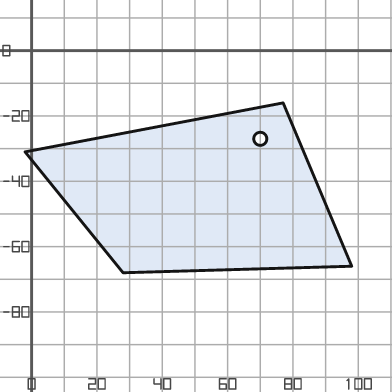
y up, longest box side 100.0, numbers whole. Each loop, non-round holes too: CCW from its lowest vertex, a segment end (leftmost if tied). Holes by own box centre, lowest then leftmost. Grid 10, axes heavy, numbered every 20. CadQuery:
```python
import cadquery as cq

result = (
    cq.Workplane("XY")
    .moveTo(28.0, -68.0)
    .lineTo(98.0, -66.0)
    .lineTo(77.0, -16.0)
    .lineTo(-2.0, -31.0)
    .close()
    .moveTo(70.0, -27.0)
    .circle(2.0)
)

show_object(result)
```